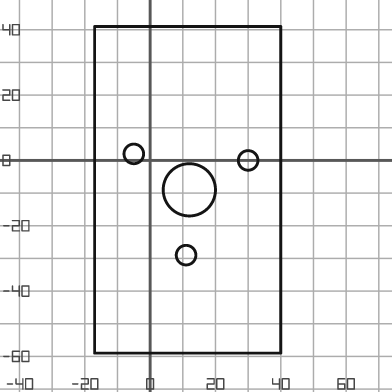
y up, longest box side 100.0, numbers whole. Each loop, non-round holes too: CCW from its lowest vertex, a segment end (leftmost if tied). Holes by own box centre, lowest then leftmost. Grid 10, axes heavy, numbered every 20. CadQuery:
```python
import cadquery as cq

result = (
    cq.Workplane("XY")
    .moveTo(-17.0, -59.0)
    .lineTo(40.0, -59.0)
    .lineTo(40.0, 41.0)
    .lineTo(-17.0, 41.0)
    .close()
    .moveTo(11.0, -29.0)
    .circle(3.0)
    .moveTo(12.0, -9.0)
    .circle(8.0)
    .moveTo(30.0, 0.0)
    .circle(3.0)
    .moveTo(-5.0, 2.0)
    .circle(3.0)
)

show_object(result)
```